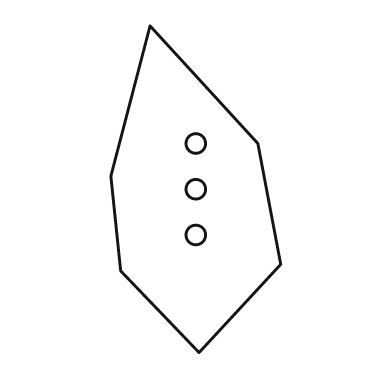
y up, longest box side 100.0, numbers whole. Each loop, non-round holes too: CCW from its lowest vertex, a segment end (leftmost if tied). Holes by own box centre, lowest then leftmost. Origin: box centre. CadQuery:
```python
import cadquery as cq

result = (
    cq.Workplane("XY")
    .moveTo(1.0, -50.0)
    .lineTo(26.0, -23.0)
    .lineTo(19.0, 14.0)
    .lineTo(-14.0, 50.0)
    .lineTo(-26.0, 4.0)
    .lineTo(-23.0, -25.0)
    .close()
    .moveTo(0.0, -14.0)
    .circle(3.0)
    .moveTo(0.0, 0.0)
    .circle(3.0)
    .moveTo(0.0, 14.0)
    .circle(3.0)
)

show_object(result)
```